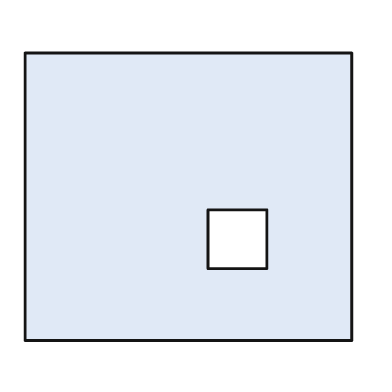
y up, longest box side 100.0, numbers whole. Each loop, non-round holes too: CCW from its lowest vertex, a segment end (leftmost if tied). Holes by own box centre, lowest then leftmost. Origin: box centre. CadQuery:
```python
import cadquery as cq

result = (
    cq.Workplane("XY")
    .moveTo(-50.0, -44.0)
    .lineTo(50.0, -44.0)
    .lineTo(50.0, 44.0)
    .lineTo(-50.0, 44.0)
    .close()
    .moveTo(6.0, -22.0)
    .lineTo(24.0, -22.0)
    .lineTo(24.0, -4.0)
    .lineTo(6.0, -4.0)
    .close()
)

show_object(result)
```